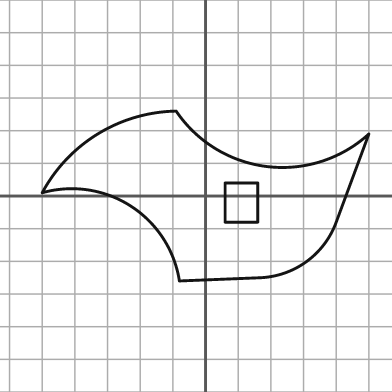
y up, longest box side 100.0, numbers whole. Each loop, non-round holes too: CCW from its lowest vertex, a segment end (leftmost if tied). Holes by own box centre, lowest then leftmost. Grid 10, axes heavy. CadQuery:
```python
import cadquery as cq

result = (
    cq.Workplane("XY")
    .moveTo(-8.0, -26.0)
    .lineTo(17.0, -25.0)
    .threePointArc((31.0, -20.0), (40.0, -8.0))
    .lineTo(50.0, 19.0)
    .threePointArc((19.0, 9.0), (-9.0, 26.0))
    .threePointArc((-33.0, 19.0), (-50.0, 1.0))
    .threePointArc((-23.0, -3.0), (-8.0, -26.0))
    .close()
    .moveTo(6.0, -8.0)
    .lineTo(16.0, -8.0)
    .lineTo(16.0, 4.0)
    .lineTo(6.0, 4.0)
    .close()
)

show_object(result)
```